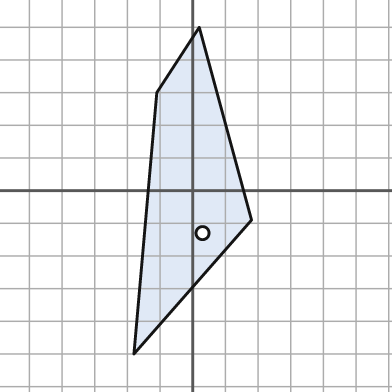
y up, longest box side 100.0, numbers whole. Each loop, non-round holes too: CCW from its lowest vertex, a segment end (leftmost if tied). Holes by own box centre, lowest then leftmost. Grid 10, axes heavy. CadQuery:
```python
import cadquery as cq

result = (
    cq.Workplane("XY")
    .moveTo(-18.0, -50.0)
    .lineTo(18.0, -9.0)
    .lineTo(2.0, 50.0)
    .lineTo(-11.0, 30.0)
    .close()
    .moveTo(3.0, -13.0)
    .circle(2.0)
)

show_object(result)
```